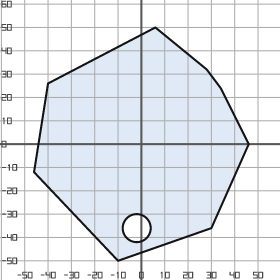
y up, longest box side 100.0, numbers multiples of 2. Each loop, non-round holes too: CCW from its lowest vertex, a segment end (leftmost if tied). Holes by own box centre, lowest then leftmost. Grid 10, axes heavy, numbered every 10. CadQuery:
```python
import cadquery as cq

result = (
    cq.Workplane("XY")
    .moveTo(-10.0, -50.0)
    .lineTo(30.0, -36.0)
    .lineTo(46.0, 0.0)
    .lineTo(34.0, 24.0)
    .lineTo(28.0, 32.0)
    .lineTo(6.0, 50.0)
    .lineTo(-40.0, 26.0)
    .lineTo(-46.0, -12.0)
    .close()
    .moveTo(-2.0, -36.0)
    .circle(6.0)
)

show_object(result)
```